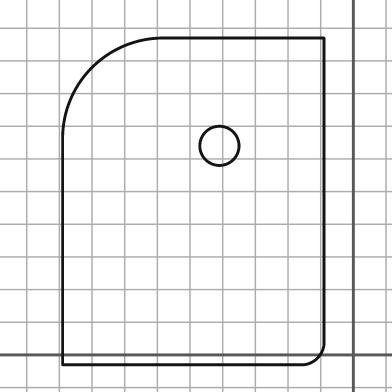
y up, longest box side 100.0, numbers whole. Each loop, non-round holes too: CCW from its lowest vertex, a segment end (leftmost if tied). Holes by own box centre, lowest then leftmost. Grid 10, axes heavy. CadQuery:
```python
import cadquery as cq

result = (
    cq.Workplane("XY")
    .moveTo(-89.0, -3.0)
    .lineTo(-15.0, -3.0)
    .threePointArc((-11.0, -1.0), (-9.0, 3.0))
    .lineTo(-9.0, 97.0)
    .lineTo(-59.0, 97.0)
    .threePointArc((-80.0, 88.0), (-89.0, 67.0))
    .close()
    .moveTo(-41.0, 64.0)
    .circle(6.0)
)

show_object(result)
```